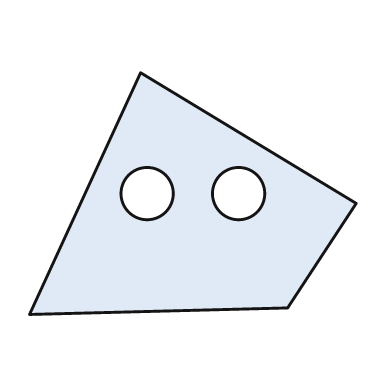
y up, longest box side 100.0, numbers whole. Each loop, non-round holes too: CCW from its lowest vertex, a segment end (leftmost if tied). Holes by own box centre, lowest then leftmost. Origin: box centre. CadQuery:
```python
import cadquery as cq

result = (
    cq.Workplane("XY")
    .moveTo(-50.0, -37.0)
    .lineTo(29.0, -35.0)
    .lineTo(50.0, -3.0)
    .lineTo(-16.0, 37.0)
    .close()
    .moveTo(-14.0, 0.0)
    .circle(8.0)
    .moveTo(14.0, 0.0)
    .circle(8.0)
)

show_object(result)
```